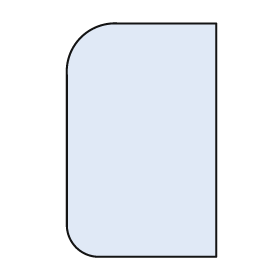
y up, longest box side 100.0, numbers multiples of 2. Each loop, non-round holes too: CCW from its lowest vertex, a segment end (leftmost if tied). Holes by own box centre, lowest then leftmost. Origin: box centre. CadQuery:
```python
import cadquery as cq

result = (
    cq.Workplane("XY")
    .moveTo(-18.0, -50.0)
    .lineTo(32.0, -50.0)
    .lineTo(32.0, 50.0)
    .lineTo(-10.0, 50.0)
    .threePointArc((-26.0, 44.0), (-32.0, 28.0))
    .lineTo(-32.0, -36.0)
    .threePointArc((-28.0, -46.0), (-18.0, -50.0))
    .close()
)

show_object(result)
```